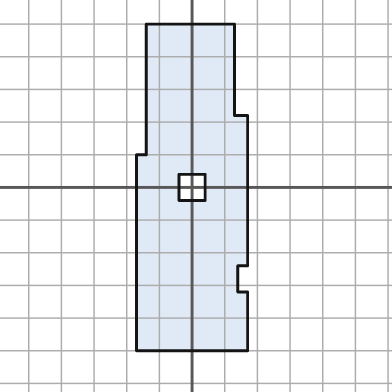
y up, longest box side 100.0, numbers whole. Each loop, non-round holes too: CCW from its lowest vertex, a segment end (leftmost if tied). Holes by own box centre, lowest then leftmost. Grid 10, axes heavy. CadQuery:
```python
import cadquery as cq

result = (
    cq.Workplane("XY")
    .moveTo(-17.0, -50.0)
    .lineTo(17.0, -50.0)
    .lineTo(17.0, -32.0)
    .lineTo(14.0, -32.0)
    .lineTo(14.0, -24.0)
    .lineTo(17.0, -24.0)
    .lineTo(17.0, 22.0)
    .lineTo(13.0, 22.0)
    .lineTo(13.0, 50.0)
    .lineTo(-14.0, 50.0)
    .lineTo(-14.0, 10.0)
    .lineTo(-17.0, 10.0)
    .close()
    .moveTo(-4.0, -4.0)
    .lineTo(4.0, -4.0)
    .lineTo(4.0, 4.0)
    .lineTo(-4.0, 4.0)
    .close()
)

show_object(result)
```